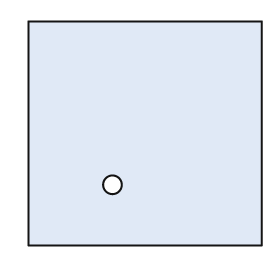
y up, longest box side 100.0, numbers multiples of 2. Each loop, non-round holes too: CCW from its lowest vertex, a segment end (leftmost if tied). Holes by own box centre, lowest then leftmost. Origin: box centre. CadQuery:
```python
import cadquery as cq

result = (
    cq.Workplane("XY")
    .moveTo(-50.0, -48.0)
    .lineTo(50.0, -48.0)
    .lineTo(50.0, 48.0)
    .lineTo(-50.0, 48.0)
    .close()
    .moveTo(-14.0, -22.0)
    .circle(4.0)
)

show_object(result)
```